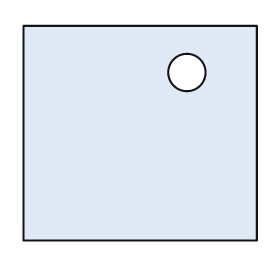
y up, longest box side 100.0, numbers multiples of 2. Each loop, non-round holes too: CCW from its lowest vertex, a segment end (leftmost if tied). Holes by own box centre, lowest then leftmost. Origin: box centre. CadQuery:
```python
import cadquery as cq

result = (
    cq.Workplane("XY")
    .moveTo(-50.0, -46.0)
    .lineTo(50.0, -46.0)
    .lineTo(50.0, 46.0)
    .lineTo(-50.0, 46.0)
    .close()
    .moveTo(20.0, 26.0)
    .circle(8.0)
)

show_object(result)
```